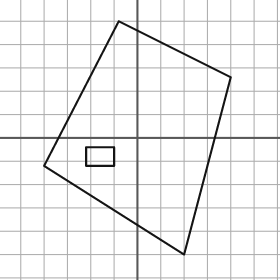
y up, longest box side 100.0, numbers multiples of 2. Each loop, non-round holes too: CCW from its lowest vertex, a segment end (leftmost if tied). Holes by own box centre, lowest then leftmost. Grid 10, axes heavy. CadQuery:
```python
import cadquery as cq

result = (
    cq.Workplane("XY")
    .moveTo(20.0, -50.0)
    .lineTo(40.0, 26.0)
    .lineTo(-8.0, 50.0)
    .lineTo(-40.0, -12.0)
    .close()
    .moveTo(-22.0, -12.0)
    .lineTo(-10.0, -12.0)
    .lineTo(-10.0, -4.0)
    .lineTo(-22.0, -4.0)
    .close()
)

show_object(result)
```